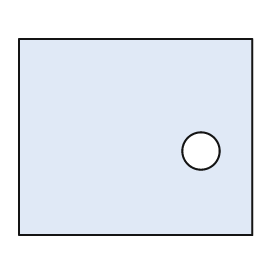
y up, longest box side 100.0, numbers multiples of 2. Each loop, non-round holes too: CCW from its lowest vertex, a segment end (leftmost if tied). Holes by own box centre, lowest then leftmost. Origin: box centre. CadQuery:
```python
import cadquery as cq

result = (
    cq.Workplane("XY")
    .moveTo(-50.0, -42.0)
    .lineTo(50.0, -42.0)
    .lineTo(50.0, 42.0)
    .lineTo(-50.0, 42.0)
    .close()
    .moveTo(28.0, -6.0)
    .circle(8.0)
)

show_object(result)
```